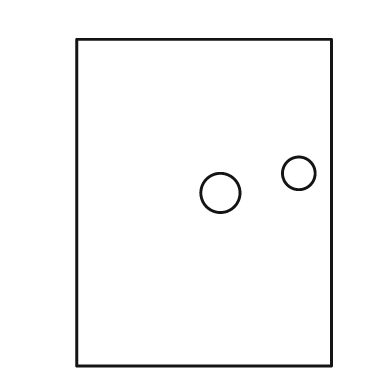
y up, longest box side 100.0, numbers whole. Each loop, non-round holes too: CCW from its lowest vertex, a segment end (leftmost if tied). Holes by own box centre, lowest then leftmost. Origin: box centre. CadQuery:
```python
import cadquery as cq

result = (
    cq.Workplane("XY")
    .moveTo(-39.0, -50.0)
    .lineTo(39.0, -50.0)
    .lineTo(39.0, 50.0)
    .lineTo(-39.0, 50.0)
    .close()
    .moveTo(5.0, 3.0)
    .circle(6.0)
    .moveTo(29.0, 9.0)
    .circle(5.0)
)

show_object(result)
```